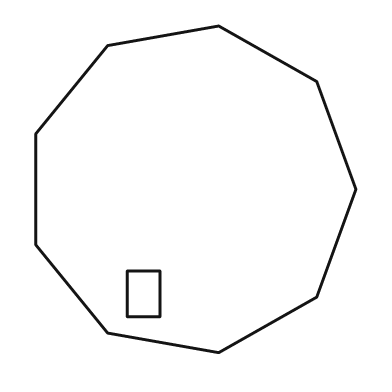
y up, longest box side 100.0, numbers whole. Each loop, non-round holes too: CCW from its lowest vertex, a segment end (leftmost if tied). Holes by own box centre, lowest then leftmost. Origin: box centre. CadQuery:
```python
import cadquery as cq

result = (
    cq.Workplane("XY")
    .moveTo(7.0, -50.0)
    .lineTo(37.0, -33.0)
    .lineTo(49.0, 0.0)
    .lineTo(37.0, 33.0)
    .lineTo(7.0, 50.0)
    .lineTo(-27.0, 44.0)
    .lineTo(-49.0, 17.0)
    .lineTo(-49.0, -17.0)
    .lineTo(-27.0, -44.0)
    .close()
    .moveTo(-21.0, -39.0)
    .lineTo(-11.0, -39.0)
    .lineTo(-11.0, -25.0)
    .lineTo(-21.0, -25.0)
    .close()
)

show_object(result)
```